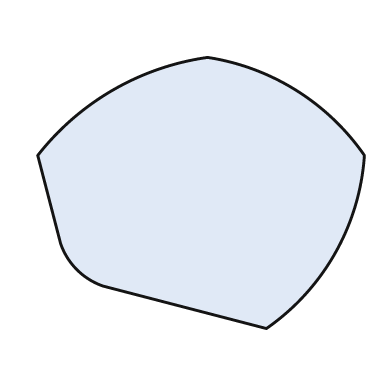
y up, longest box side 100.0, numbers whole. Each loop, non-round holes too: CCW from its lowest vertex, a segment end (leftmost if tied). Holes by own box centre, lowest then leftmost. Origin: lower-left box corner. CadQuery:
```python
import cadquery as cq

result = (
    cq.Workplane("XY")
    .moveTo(70.0, 0.0)
    .threePointArc((91.0, 23.0), (100.0, 53.0))
    .threePointArc((79.0, 73.0), (52.0, 83.0))
    .threePointArc((23.0, 73.0), (0.0, 53.0))
    .lineTo(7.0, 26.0)
    .threePointArc((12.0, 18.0), (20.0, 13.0))
    .close()
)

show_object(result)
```